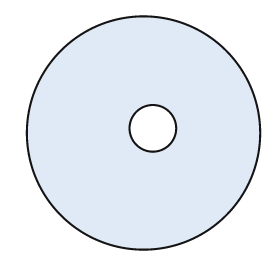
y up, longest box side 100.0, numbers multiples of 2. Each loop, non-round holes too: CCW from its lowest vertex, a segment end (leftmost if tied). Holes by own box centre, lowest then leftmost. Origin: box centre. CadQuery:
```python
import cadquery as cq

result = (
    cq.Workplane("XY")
    .moveTo(0.0, 0.0)
    .circle(50.0)
    .moveTo(4.0, 2.0)
    .circle(10.0)
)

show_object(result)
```